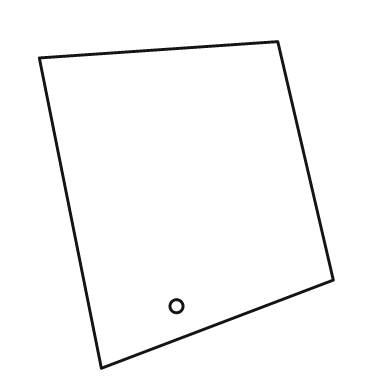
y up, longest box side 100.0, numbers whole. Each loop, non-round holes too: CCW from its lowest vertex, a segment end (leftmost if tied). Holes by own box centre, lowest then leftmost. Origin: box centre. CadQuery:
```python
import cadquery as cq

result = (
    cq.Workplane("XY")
    .moveTo(-26.0, -50.0)
    .lineTo(45.0, -23.0)
    .lineTo(28.0, 50.0)
    .lineTo(-45.0, 45.0)
    .close()
    .moveTo(-3.0, -31.0)
    .circle(2.0)
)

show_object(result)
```